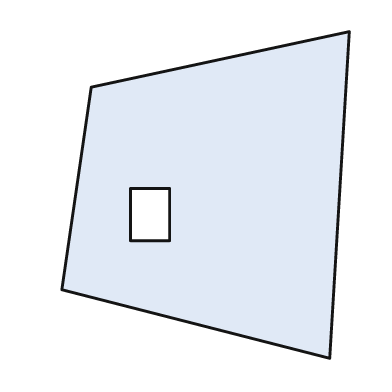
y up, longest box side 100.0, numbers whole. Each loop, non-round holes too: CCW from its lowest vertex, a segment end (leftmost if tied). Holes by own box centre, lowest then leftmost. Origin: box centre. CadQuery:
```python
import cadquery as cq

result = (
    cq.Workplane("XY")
    .moveTo(38.0, -50.0)
    .lineTo(44.0, 50.0)
    .lineTo(-35.0, 33.0)
    .lineTo(-44.0, -29.0)
    .close()
    .moveTo(-23.0, -14.0)
    .lineTo(-11.0, -14.0)
    .lineTo(-11.0, 2.0)
    .lineTo(-23.0, 2.0)
    .close()
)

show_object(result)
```